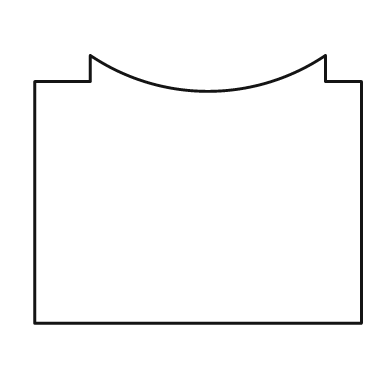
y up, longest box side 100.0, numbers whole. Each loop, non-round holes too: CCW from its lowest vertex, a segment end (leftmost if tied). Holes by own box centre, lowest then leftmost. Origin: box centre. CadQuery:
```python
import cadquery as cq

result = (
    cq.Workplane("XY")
    .moveTo(-50.0, -41.0)
    .lineTo(50.0, -41.0)
    .lineTo(50.0, 33.0)
    .lineTo(39.0, 33.0)
    .lineTo(39.0, 41.0)
    .threePointArc((3.0, 30.0), (-33.0, 41.0))
    .lineTo(-33.0, 33.0)
    .lineTo(-50.0, 33.0)
    .close()
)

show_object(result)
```